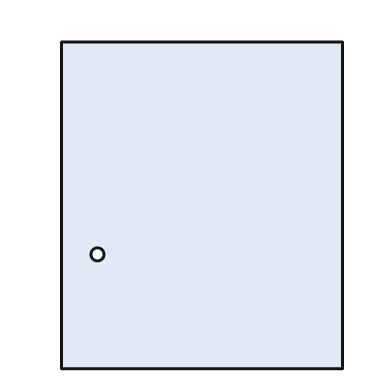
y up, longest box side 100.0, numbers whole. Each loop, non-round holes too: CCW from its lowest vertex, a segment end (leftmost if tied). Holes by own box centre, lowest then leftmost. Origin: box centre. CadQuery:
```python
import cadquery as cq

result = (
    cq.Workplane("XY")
    .moveTo(-43.0, -50.0)
    .lineTo(43.0, -50.0)
    .lineTo(43.0, 50.0)
    .lineTo(-43.0, 50.0)
    .close()
    .moveTo(-32.0, -15.0)
    .circle(2.0)
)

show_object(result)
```